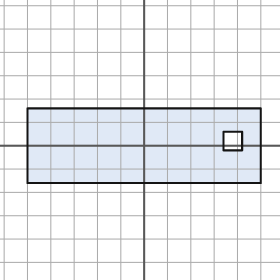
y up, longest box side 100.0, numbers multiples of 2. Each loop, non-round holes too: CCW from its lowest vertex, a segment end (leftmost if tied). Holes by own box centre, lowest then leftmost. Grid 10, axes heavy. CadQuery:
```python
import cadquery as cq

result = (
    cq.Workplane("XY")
    .moveTo(-50.0, -16.0)
    .lineTo(50.0, -16.0)
    .lineTo(50.0, 16.0)
    .lineTo(-50.0, 16.0)
    .close()
    .moveTo(34.0, -2.0)
    .lineTo(42.0, -2.0)
    .lineTo(42.0, 6.0)
    .lineTo(34.0, 6.0)
    .close()
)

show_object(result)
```